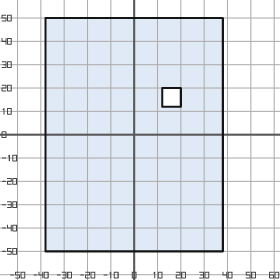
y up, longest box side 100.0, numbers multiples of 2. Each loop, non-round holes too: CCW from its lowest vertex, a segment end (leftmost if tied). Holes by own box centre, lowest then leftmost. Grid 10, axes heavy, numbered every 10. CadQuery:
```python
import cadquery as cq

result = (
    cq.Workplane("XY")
    .moveTo(-38.0, -50.0)
    .lineTo(38.0, -50.0)
    .lineTo(38.0, 50.0)
    .lineTo(-38.0, 50.0)
    .close()
    .moveTo(12.0, 12.0)
    .lineTo(20.0, 12.0)
    .lineTo(20.0, 20.0)
    .lineTo(12.0, 20.0)
    .close()
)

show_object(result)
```